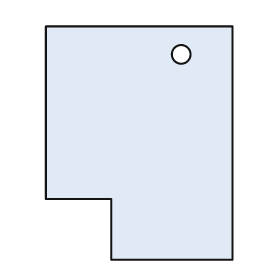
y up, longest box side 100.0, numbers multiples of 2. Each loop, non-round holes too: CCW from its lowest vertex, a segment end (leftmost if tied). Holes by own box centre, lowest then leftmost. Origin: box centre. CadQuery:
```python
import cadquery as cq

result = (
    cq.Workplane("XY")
    .moveTo(-12.0, -50.0)
    .lineTo(40.0, -50.0)
    .lineTo(40.0, 50.0)
    .lineTo(-40.0, 50.0)
    .lineTo(-40.0, -24.0)
    .lineTo(-12.0, -24.0)
    .close()
    .moveTo(18.0, 38.0)
    .circle(4.0)
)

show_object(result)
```